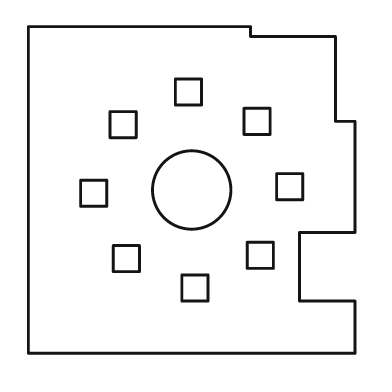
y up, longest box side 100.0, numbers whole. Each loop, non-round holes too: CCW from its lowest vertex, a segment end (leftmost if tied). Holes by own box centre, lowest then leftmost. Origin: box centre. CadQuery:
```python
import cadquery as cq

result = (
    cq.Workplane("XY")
    .moveTo(-50.0, -50.0)
    .lineTo(50.0, -50.0)
    .lineTo(50.0, -34.0)
    .lineTo(33.0, -34.0)
    .lineTo(33.0, -13.0)
    .lineTo(50.0, -13.0)
    .lineTo(50.0, 21.0)
    .lineTo(44.0, 21.0)
    .lineTo(44.0, 47.0)
    .lineTo(18.0, 47.0)
    .lineTo(18.0, 50.0)
    .lineTo(-50.0, 50.0)
    .close()
    .moveTo(-3.0, -34.0)
    .lineTo(5.0, -34.0)
    .lineTo(5.0, -26.0)
    .lineTo(-3.0, -26.0)
    .close()
    .moveTo(-24.0, -25.0)
    .lineTo(-16.0, -25.0)
    .lineTo(-16.0, -17.0)
    .lineTo(-24.0, -17.0)
    .close()
    .moveTo(17.0, -24.0)
    .lineTo(25.0, -24.0)
    .lineTo(25.0, -16.0)
    .lineTo(17.0, -16.0)
    .close()
    .moveTo(-34.0, -5.0)
    .lineTo(-26.0, -5.0)
    .lineTo(-26.0, 3.0)
    .lineTo(-34.0, 3.0)
    .close()
    .moveTo(0.0, 0.0)
    .circle(12.0)
    .moveTo(26.0, -3.0)
    .lineTo(34.0, -3.0)
    .lineTo(34.0, 5.0)
    .lineTo(26.0, 5.0)
    .close()
    .moveTo(-25.0, 16.0)
    .lineTo(-17.0, 16.0)
    .lineTo(-17.0, 24.0)
    .lineTo(-25.0, 24.0)
    .close()
    .moveTo(16.0, 17.0)
    .lineTo(24.0, 17.0)
    .lineTo(24.0, 25.0)
    .lineTo(16.0, 25.0)
    .close()
    .moveTo(-5.0, 26.0)
    .lineTo(3.0, 26.0)
    .lineTo(3.0, 34.0)
    .lineTo(-5.0, 34.0)
    .close()
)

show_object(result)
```